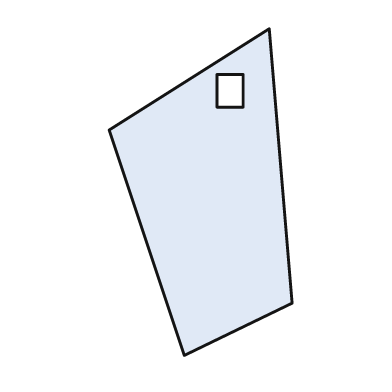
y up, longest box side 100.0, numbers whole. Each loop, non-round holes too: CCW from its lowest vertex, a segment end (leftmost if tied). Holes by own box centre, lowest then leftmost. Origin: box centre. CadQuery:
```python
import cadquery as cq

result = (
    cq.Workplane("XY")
    .moveTo(-5.0, -50.0)
    .lineTo(28.0, -34.0)
    .lineTo(21.0, 50.0)
    .lineTo(-28.0, 19.0)
    .close()
    .moveTo(5.0, 26.0)
    .lineTo(13.0, 26.0)
    .lineTo(13.0, 36.0)
    .lineTo(5.0, 36.0)
    .close()
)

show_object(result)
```